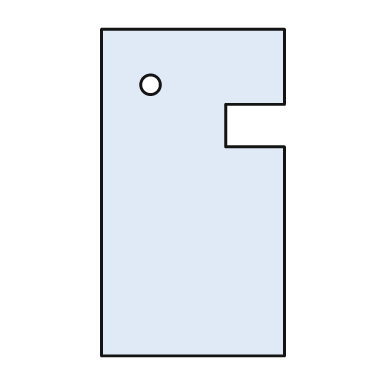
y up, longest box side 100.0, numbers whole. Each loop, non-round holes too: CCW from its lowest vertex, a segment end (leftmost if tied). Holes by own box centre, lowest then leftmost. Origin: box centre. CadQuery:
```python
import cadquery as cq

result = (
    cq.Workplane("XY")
    .moveTo(-28.0, -50.0)
    .lineTo(28.0, -50.0)
    .lineTo(28.0, 14.0)
    .lineTo(10.0, 14.0)
    .lineTo(10.0, 27.0)
    .lineTo(28.0, 27.0)
    .lineTo(28.0, 50.0)
    .lineTo(-28.0, 50.0)
    .close()
    .moveTo(-13.0, 33.0)
    .circle(3.0)
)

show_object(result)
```